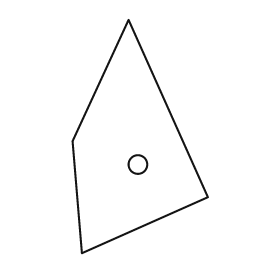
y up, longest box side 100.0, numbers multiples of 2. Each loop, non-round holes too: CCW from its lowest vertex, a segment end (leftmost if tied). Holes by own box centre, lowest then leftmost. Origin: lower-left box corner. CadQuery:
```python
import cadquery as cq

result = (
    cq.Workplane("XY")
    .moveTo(4.0, 0.0)
    .lineTo(58.0, 24.0)
    .lineTo(24.0, 100.0)
    .lineTo(0.0, 48.0)
    .close()
    .moveTo(28.0, 38.0)
    .circle(4.0)
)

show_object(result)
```